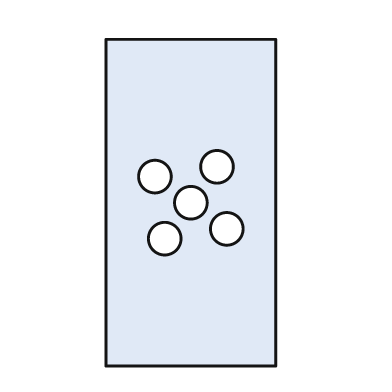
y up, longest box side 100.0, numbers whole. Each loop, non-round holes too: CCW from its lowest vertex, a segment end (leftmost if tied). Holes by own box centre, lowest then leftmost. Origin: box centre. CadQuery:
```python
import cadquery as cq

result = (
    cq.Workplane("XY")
    .moveTo(-26.0, -50.0)
    .lineTo(26.0, -50.0)
    .lineTo(26.0, 50.0)
    .lineTo(-26.0, 50.0)
    .close()
    .moveTo(-8.0, -11.0)
    .circle(5.0)
    .moveTo(11.0, -8.0)
    .circle(5.0)
    .moveTo(0.0, 0.0)
    .circle(5.0)
    .moveTo(-11.0, 8.0)
    .circle(5.0)
    .moveTo(8.0, 11.0)
    .circle(5.0)
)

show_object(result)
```